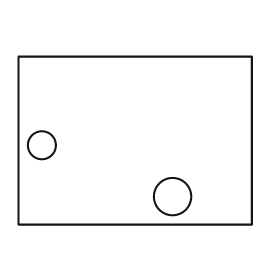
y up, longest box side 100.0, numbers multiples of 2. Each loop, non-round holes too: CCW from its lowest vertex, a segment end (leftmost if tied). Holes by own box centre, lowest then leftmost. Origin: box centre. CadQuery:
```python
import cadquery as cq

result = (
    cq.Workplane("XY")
    .moveTo(-50.0, -36.0)
    .lineTo(50.0, -36.0)
    .lineTo(50.0, 36.0)
    .lineTo(-50.0, 36.0)
    .close()
    .moveTo(16.0, -24.0)
    .circle(8.0)
    .moveTo(-40.0, -2.0)
    .circle(6.0)
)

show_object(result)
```